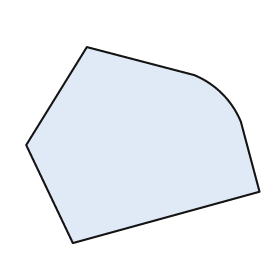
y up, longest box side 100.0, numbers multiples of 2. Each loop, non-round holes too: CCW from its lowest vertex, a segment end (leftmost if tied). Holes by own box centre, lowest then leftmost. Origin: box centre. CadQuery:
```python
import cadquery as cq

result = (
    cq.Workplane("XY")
    .moveTo(-30.0, -42.0)
    .lineTo(50.0, -20.0)
    .lineTo(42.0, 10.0)
    .threePointArc((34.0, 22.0), (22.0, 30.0))
    .lineTo(-24.0, 42.0)
    .lineTo(-50.0, 0.0)
    .close()
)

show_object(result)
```